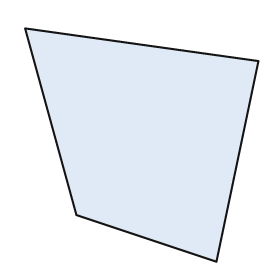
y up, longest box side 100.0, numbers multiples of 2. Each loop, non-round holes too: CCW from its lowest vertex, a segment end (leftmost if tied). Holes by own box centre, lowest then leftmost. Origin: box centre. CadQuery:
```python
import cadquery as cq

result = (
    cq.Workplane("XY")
    .moveTo(32.0, -50.0)
    .lineTo(50.0, 36.0)
    .lineTo(-50.0, 50.0)
    .lineTo(-28.0, -30.0)
    .close()
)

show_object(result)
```